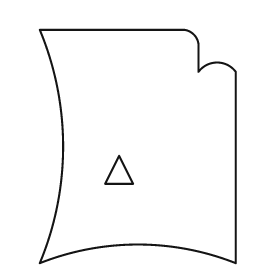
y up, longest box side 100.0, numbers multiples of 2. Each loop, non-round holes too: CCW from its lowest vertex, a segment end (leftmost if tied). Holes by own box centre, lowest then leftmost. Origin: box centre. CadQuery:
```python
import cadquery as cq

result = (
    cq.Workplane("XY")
    .moveTo(-42.0, -50.0)
    .threePointArc((0.0, -42.0), (42.0, -50.0))
    .lineTo(42.0, 32.0)
    .threePointArc((34.0, 36.0), (26.0, 32.0))
    .lineTo(26.0, 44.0)
    .threePointArc((24.0, 48.0), (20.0, 50.0))
    .lineTo(-42.0, 50.0)
    .threePointArc((-32.0, 0.0), (-42.0, -50.0))
    .close()
    .moveTo(-14.0, -16.0)
    .lineTo(-2.0, -16.0)
    .lineTo(-8.0, -4.0)
    .close()
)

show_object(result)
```